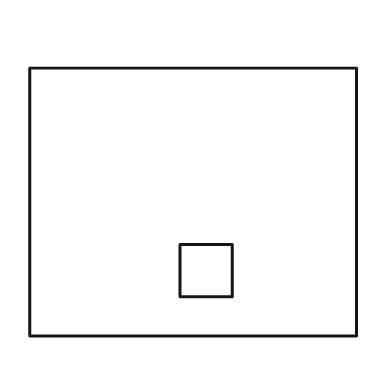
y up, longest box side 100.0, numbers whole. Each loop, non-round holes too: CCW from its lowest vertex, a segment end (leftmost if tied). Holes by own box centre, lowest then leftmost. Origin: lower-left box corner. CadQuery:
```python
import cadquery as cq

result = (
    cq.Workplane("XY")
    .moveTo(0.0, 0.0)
    .lineTo(100.0, 0.0)
    .lineTo(100.0, 82.0)
    .lineTo(0.0, 82.0)
    .close()
    .moveTo(46.0, 12.0)
    .lineTo(62.0, 12.0)
    .lineTo(62.0, 28.0)
    .lineTo(46.0, 28.0)
    .close()
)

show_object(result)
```